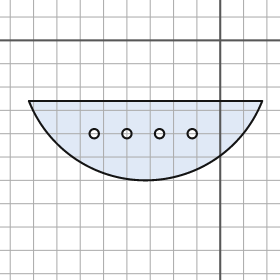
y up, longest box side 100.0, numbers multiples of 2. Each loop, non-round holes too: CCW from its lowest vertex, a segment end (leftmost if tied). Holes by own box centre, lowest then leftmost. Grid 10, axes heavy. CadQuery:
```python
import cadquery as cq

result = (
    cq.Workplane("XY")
    .moveTo(-82.0, -26.0)
    .threePointArc((-32.0, -60.0), (18.0, -26.0))
    .close()
    .moveTo(-54.0, -40.0)
    .circle(2.0)
    .moveTo(-40.0, -40.0)
    .circle(2.0)
    .moveTo(-26.0, -40.0)
    .circle(2.0)
    .moveTo(-12.0, -40.0)
    .circle(2.0)
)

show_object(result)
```